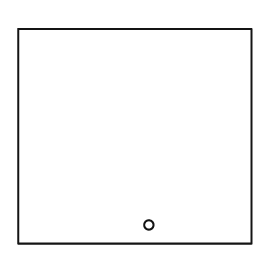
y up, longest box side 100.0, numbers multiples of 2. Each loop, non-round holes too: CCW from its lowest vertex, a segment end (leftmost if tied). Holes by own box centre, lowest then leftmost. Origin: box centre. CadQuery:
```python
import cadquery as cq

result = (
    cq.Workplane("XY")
    .moveTo(-50.0, -46.0)
    .lineTo(50.0, -46.0)
    .lineTo(50.0, 46.0)
    .lineTo(-50.0, 46.0)
    .close()
    .moveTo(6.0, -38.0)
    .circle(2.0)
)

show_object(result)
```